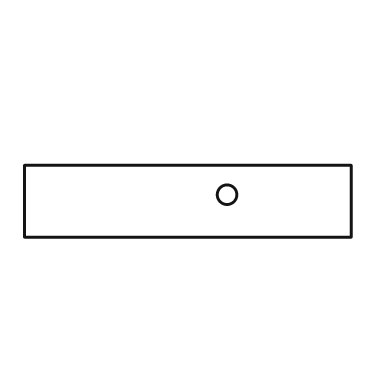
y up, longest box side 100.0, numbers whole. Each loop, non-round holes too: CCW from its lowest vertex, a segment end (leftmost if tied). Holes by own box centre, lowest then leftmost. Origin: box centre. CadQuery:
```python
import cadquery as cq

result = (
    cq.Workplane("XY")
    .moveTo(-50.0, -11.0)
    .lineTo(50.0, -11.0)
    .lineTo(50.0, 11.0)
    .lineTo(-50.0, 11.0)
    .close()
    .moveTo(12.0, 2.0)
    .circle(3.0)
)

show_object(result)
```